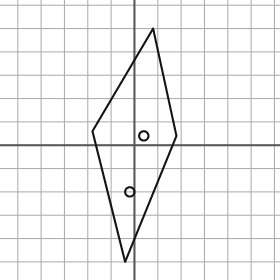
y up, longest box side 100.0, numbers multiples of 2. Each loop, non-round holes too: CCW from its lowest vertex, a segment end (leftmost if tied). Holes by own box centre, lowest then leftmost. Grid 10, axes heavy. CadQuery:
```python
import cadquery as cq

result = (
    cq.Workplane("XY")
    .moveTo(-4.0, -50.0)
    .lineTo(18.0, 4.0)
    .lineTo(8.0, 50.0)
    .lineTo(-18.0, 6.0)
    .close()
    .moveTo(-2.0, -20.0)
    .circle(2.0)
    .moveTo(4.0, 4.0)
    .circle(2.0)
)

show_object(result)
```